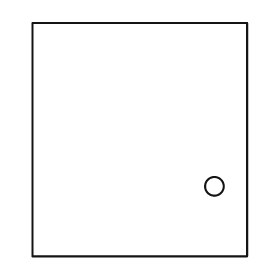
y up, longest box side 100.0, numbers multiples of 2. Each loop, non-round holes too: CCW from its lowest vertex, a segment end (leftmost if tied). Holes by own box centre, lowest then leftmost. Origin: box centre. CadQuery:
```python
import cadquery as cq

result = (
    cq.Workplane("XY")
    .moveTo(-46.0, -50.0)
    .lineTo(46.0, -50.0)
    .lineTo(46.0, 50.0)
    .lineTo(-46.0, 50.0)
    .close()
    .moveTo(32.0, -20.0)
    .circle(4.0)
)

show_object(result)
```